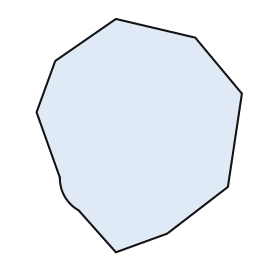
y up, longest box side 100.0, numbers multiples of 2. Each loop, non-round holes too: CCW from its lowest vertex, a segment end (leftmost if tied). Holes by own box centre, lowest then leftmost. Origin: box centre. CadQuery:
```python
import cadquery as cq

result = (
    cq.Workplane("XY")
    .moveTo(-10.0, -50.0)
    .lineTo(12.0, -42.0)
    .lineTo(38.0, -22.0)
    .lineTo(44.0, 18.0)
    .lineTo(24.0, 42.0)
    .lineTo(-10.0, 50.0)
    .lineTo(-36.0, 32.0)
    .lineTo(-44.0, 10.0)
    .lineTo(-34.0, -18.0)
    .threePointArc((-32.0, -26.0), (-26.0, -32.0))
    .close()
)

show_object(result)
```